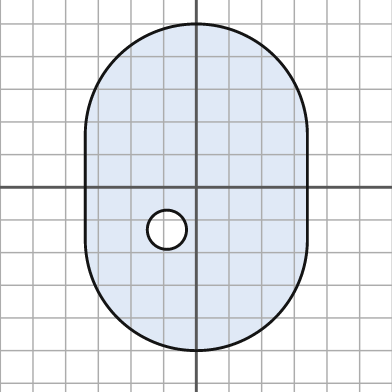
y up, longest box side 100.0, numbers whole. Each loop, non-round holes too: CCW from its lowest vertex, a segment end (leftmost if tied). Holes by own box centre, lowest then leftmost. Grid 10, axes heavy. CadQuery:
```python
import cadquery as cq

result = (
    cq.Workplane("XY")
    .moveTo(-34.0, -16.0)
    .threePointArc((0.0, -50.0), (34.0, -16.0))
    .lineTo(34.0, 16.0)
    .threePointArc((0.0, 50.0), (-34.0, 16.0))
    .close()
    .moveTo(-9.0, -13.0)
    .circle(6.0)
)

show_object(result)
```